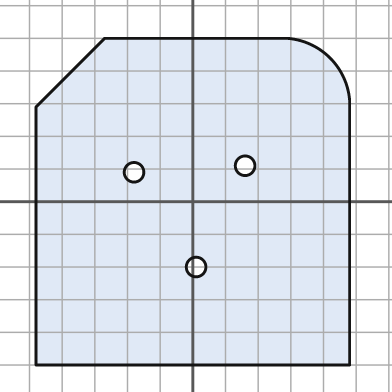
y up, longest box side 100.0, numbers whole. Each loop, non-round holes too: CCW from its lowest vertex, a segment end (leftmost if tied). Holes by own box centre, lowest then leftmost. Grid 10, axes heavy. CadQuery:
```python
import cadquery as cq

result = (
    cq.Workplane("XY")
    .moveTo(-48.0, -50.0)
    .lineTo(48.0, -50.0)
    .lineTo(48.0, 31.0)
    .threePointArc((42.0, 44.0), (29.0, 50.0))
    .lineTo(-27.0, 50.0)
    .lineTo(-48.0, 29.0)
    .close()
    .moveTo(1.0, -20.0)
    .circle(3.0)
    .moveTo(-18.0, 9.0)
    .circle(3.0)
    .moveTo(16.0, 11.0)
    .circle(3.0)
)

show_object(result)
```